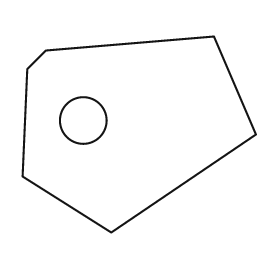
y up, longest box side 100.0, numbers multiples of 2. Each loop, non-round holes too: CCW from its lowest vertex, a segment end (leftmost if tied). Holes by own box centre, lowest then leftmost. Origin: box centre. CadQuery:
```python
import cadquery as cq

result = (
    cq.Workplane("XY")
    .moveTo(-12.0, -42.0)
    .lineTo(50.0, 0.0)
    .lineTo(32.0, 42.0)
    .lineTo(-40.0, 36.0)
    .lineTo(-48.0, 28.0)
    .lineTo(-50.0, -18.0)
    .close()
    .moveTo(-24.0, 6.0)
    .circle(10.0)
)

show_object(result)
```